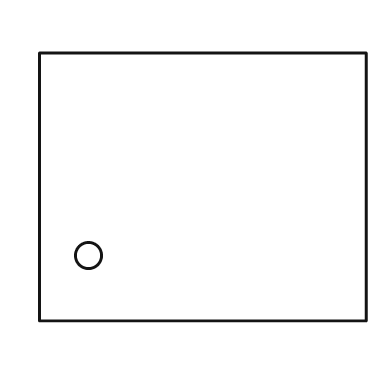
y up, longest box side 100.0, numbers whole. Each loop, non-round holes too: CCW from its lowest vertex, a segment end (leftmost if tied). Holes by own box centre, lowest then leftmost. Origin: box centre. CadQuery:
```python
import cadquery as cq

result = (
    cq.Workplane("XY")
    .moveTo(-50.0, -41.0)
    .lineTo(50.0, -41.0)
    .lineTo(50.0, 41.0)
    .lineTo(-50.0, 41.0)
    .close()
    .moveTo(-35.0, -21.0)
    .circle(4.0)
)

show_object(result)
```